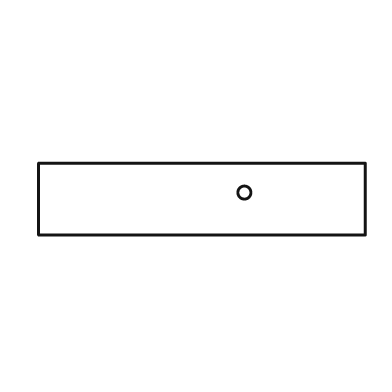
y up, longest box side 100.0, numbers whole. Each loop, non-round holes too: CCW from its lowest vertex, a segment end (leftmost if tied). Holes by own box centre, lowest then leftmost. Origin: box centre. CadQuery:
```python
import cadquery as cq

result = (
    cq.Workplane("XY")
    .moveTo(-50.0, -11.0)
    .lineTo(50.0, -11.0)
    .lineTo(50.0, 11.0)
    .lineTo(-50.0, 11.0)
    .close()
    .moveTo(13.0, 2.0)
    .circle(2.0)
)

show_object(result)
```